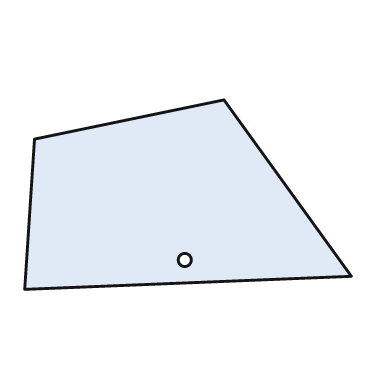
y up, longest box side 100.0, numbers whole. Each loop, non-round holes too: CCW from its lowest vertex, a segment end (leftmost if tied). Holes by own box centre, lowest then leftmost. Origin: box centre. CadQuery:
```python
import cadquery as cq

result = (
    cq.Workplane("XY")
    .moveTo(-50.0, -29.0)
    .lineTo(50.0, -25.0)
    .lineTo(11.0, 29.0)
    .lineTo(-47.0, 17.0)
    .close()
    .moveTo(-1.0, -20.0)
    .circle(2.0)
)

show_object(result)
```